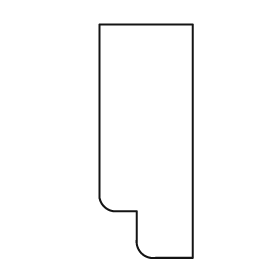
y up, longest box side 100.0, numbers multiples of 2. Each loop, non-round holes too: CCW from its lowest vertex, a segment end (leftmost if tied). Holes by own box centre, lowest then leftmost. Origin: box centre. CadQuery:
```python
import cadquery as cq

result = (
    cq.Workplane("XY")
    .moveTo(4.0, -50.0)
    .lineTo(20.0, -50.0)
    .lineTo(20.0, 50.0)
    .lineTo(-20.0, 50.0)
    .lineTo(-20.0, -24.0)
    .threePointArc((-18.0, -28.0), (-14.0, -30.0))
    .lineTo(-4.0, -30.0)
    .lineTo(-4.0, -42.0)
    .threePointArc((-2.0, -48.0), (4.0, -50.0))
    .close()
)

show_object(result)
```